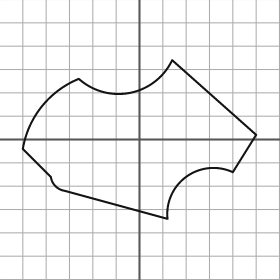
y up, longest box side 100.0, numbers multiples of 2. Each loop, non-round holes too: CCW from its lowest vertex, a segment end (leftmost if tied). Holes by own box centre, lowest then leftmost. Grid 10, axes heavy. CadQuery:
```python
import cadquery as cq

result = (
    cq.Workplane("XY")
    .moveTo(12.0, -34.0)
    .threePointArc((20.0, -16.0), (40.0, -14.0))
    .lineTo(50.0, 2.0)
    .lineTo(14.0, 34.0)
    .threePointArc((-4.0, 20.0), (-26.0, 26.0))
    .threePointArc((-42.0, 14.0), (-50.0, -4.0))
    .lineTo(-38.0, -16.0)
    .threePointArc((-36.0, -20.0), (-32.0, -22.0))
    .close()
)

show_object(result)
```